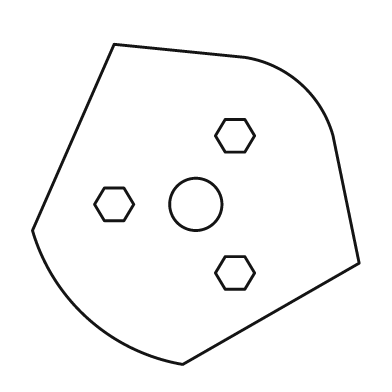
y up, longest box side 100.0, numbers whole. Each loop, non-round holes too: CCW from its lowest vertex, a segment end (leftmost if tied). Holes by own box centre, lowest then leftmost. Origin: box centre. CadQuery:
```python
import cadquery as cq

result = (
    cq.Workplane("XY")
    .moveTo(-4.0, -49.0)
    .lineTo(50.0, -18.0)
    .lineTo(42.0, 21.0)
    .threePointArc((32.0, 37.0), (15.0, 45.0))
    .lineTo(-25.0, 49.0)
    .lineTo(-50.0, -8.0)
    .threePointArc((-33.0, -35.0), (-4.0, -49.0))
    .close()
    .moveTo(9.0, -26.0)
    .lineTo(15.0, -26.0)
    .lineTo(18.0, -21.0)
    .lineTo(15.0, -16.0)
    .lineTo(9.0, -16.0)
    .lineTo(6.0, -21.0)
    .close()
    .moveTo(-28.0, -5.0)
    .lineTo(-22.0, -5.0)
    .lineTo(-19.0, 0.0)
    .lineTo(-22.0, 5.0)
    .lineTo(-28.0, 5.0)
    .lineTo(-31.0, 0.0)
    .close()
    .moveTo(0.0, 0.0)
    .circle(8.0)
    .moveTo(9.0, 16.0)
    .lineTo(15.0, 16.0)
    .lineTo(18.0, 21.0)
    .lineTo(15.0, 26.0)
    .lineTo(9.0, 26.0)
    .lineTo(6.0, 21.0)
    .close()
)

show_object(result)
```